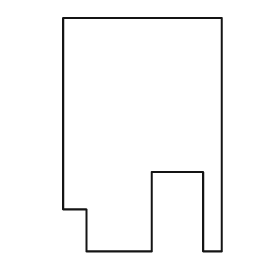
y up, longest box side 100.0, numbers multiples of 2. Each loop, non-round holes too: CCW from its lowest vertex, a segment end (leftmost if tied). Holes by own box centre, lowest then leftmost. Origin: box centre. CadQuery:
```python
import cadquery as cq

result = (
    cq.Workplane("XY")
    .moveTo(-24.0, -50.0)
    .lineTo(4.0, -50.0)
    .lineTo(4.0, -16.0)
    .lineTo(26.0, -16.0)
    .lineTo(26.0, -50.0)
    .lineTo(34.0, -50.0)
    .lineTo(34.0, 50.0)
    .lineTo(-34.0, 50.0)
    .lineTo(-34.0, -32.0)
    .lineTo(-24.0, -32.0)
    .close()
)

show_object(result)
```